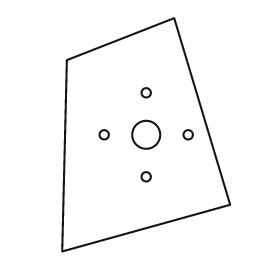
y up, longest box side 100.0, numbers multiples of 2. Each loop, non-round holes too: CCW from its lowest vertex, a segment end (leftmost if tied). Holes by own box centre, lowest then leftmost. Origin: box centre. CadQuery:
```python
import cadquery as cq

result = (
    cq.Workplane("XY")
    .moveTo(-36.0, -50.0)
    .lineTo(36.0, -30.0)
    .lineTo(12.0, 50.0)
    .lineTo(-34.0, 32.0)
    .close()
    .moveTo(0.0, -18.0)
    .circle(2.0)
    .moveTo(-18.0, 0.0)
    .circle(2.0)
    .moveTo(0.0, 0.0)
    .circle(6.0)
    .moveTo(18.0, 0.0)
    .circle(2.0)
    .moveTo(0.0, 18.0)
    .circle(2.0)
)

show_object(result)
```